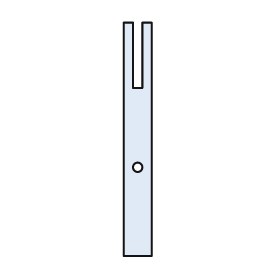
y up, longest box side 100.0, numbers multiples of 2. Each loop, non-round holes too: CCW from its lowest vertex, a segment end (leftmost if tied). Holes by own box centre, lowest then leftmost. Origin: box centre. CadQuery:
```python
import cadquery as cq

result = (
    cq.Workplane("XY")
    .moveTo(-6.0, -50.0)
    .lineTo(6.0, -50.0)
    .lineTo(6.0, 50.0)
    .lineTo(2.0, 50.0)
    .lineTo(2.0, 22.0)
    .lineTo(-2.0, 22.0)
    .lineTo(-2.0, 50.0)
    .lineTo(-6.0, 50.0)
    .close()
    .moveTo(0.0, -12.0)
    .circle(2.0)
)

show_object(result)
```